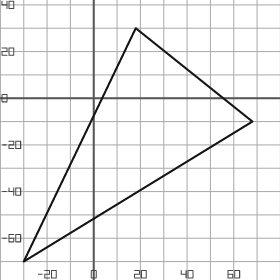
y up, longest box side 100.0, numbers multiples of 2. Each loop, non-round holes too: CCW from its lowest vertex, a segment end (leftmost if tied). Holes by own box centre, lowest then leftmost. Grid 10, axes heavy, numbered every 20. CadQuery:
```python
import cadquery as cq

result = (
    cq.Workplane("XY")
    .moveTo(-30.0, -70.0)
    .lineTo(68.0, -10.0)
    .lineTo(18.0, 30.0)
    .close()
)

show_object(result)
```